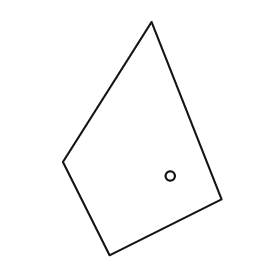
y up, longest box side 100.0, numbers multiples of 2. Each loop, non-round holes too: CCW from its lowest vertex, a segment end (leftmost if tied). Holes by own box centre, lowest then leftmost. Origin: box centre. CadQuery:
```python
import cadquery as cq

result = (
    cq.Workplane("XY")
    .moveTo(-14.0, -50.0)
    .lineTo(34.0, -26.0)
    .lineTo(4.0, 50.0)
    .lineTo(-34.0, -10.0)
    .close()
    .moveTo(12.0, -16.0)
    .circle(2.0)
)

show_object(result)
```